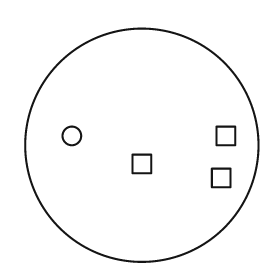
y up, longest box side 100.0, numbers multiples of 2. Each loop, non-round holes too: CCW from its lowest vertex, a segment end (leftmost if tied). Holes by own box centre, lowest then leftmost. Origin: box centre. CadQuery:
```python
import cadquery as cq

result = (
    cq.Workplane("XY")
    .moveTo(0.0, 0.0)
    .circle(50.0)
    .moveTo(30.0, -18.0)
    .lineTo(38.0, -18.0)
    .lineTo(38.0, -10.0)
    .lineTo(30.0, -10.0)
    .close()
    .moveTo(-4.0, -12.0)
    .lineTo(4.0, -12.0)
    .lineTo(4.0, -4.0)
    .lineTo(-4.0, -4.0)
    .close()
    .moveTo(-30.0, 4.0)
    .circle(4.0)
    .moveTo(32.0, 0.0)
    .lineTo(40.0, 0.0)
    .lineTo(40.0, 8.0)
    .lineTo(32.0, 8.0)
    .close()
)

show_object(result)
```